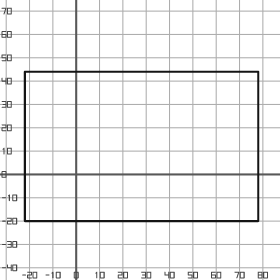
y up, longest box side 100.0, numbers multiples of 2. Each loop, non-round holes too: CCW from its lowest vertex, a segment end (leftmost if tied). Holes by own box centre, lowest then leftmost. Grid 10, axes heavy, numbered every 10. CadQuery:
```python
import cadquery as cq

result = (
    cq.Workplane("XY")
    .moveTo(-22.0, -20.0)
    .lineTo(78.0, -20.0)
    .lineTo(78.0, 44.0)
    .lineTo(-22.0, 44.0)
    .close()
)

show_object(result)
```